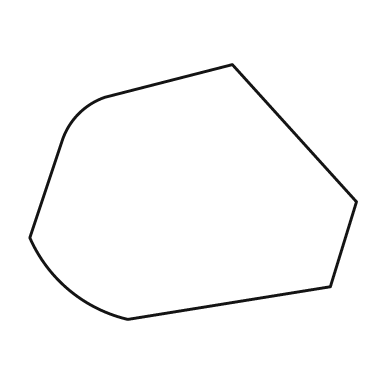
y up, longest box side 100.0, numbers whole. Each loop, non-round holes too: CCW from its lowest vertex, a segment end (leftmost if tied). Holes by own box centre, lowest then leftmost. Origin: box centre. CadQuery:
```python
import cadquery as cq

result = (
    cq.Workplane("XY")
    .moveTo(-20.0, -39.0)
    .lineTo(42.0, -29.0)
    .lineTo(50.0, -3.0)
    .lineTo(12.0, 39.0)
    .lineTo(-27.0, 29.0)
    .threePointArc((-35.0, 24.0), (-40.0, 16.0))
    .lineTo(-50.0, -14.0)
    .threePointArc((-38.0, -30.0), (-20.0, -39.0))
    .close()
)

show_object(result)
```